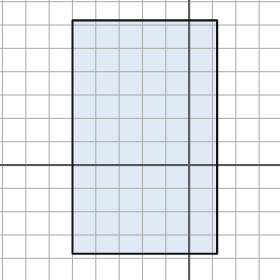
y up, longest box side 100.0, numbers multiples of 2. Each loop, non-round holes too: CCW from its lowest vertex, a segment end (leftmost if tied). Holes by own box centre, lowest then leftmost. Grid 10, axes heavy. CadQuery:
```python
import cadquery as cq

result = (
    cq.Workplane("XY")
    .moveTo(-50.0, -38.0)
    .lineTo(12.0, -38.0)
    .lineTo(12.0, 62.0)
    .lineTo(-50.0, 62.0)
    .close()
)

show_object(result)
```